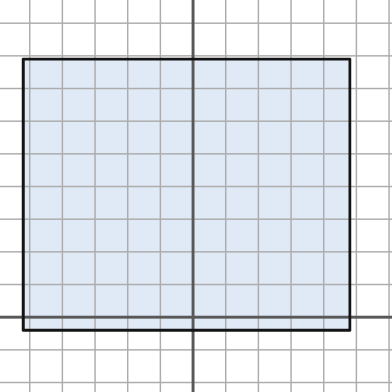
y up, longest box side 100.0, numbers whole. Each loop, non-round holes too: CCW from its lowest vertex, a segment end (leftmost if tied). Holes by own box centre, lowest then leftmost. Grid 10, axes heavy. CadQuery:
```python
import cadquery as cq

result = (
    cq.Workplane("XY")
    .moveTo(-52.0, -4.0)
    .lineTo(48.0, -4.0)
    .lineTo(48.0, 79.0)
    .lineTo(-52.0, 79.0)
    .close()
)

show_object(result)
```